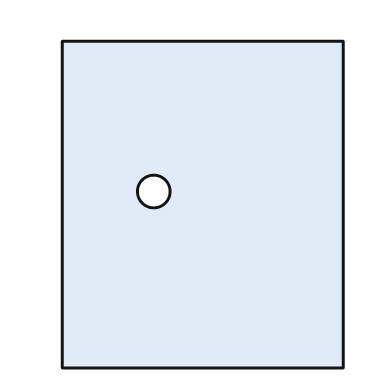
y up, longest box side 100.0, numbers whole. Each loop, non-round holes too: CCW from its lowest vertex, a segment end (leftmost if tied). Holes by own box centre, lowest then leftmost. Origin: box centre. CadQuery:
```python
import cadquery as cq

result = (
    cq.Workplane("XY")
    .moveTo(-43.0, -50.0)
    .lineTo(43.0, -50.0)
    .lineTo(43.0, 50.0)
    .lineTo(-43.0, 50.0)
    .close()
    .moveTo(-15.0, 4.0)
    .circle(5.0)
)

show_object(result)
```